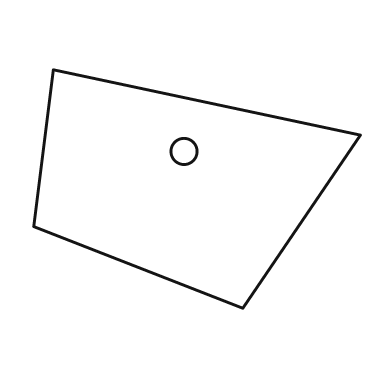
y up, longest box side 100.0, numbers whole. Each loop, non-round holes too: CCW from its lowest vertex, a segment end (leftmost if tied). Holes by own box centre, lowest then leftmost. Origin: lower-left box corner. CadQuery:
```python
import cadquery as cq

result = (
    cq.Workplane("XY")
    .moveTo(64.0, 0.0)
    .lineTo(100.0, 53.0)
    .lineTo(6.0, 73.0)
    .lineTo(0.0, 25.0)
    .close()
    .moveTo(46.0, 48.0)
    .circle(4.0)
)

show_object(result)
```